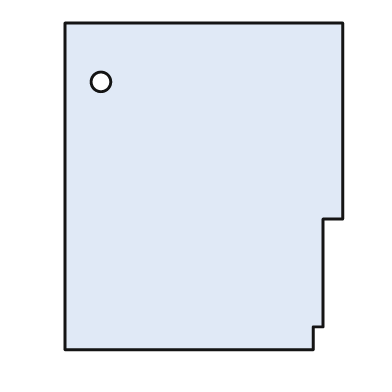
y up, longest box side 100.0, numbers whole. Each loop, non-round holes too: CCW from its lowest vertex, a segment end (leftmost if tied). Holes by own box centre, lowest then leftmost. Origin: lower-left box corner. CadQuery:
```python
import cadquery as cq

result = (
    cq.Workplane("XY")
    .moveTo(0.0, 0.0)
    .lineTo(76.0, 0.0)
    .lineTo(76.0, 7.0)
    .lineTo(79.0, 7.0)
    .lineTo(79.0, 40.0)
    .lineTo(85.0, 40.0)
    .lineTo(85.0, 100.0)
    .lineTo(0.0, 100.0)
    .close()
    .moveTo(11.0, 82.0)
    .circle(3.0)
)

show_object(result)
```